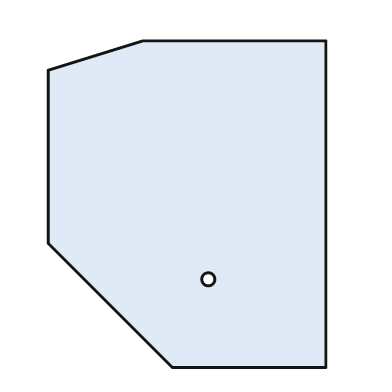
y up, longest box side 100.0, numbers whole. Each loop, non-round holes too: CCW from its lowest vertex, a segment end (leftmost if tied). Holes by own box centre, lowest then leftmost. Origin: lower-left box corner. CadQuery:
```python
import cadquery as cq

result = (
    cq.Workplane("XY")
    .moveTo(38.0, 0.0)
    .lineTo(85.0, 0.0)
    .lineTo(85.0, 100.0)
    .lineTo(29.0, 100.0)
    .lineTo(0.0, 91.0)
    .lineTo(0.0, 38.0)
    .close()
    .moveTo(49.0, 27.0)
    .circle(2.0)
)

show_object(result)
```